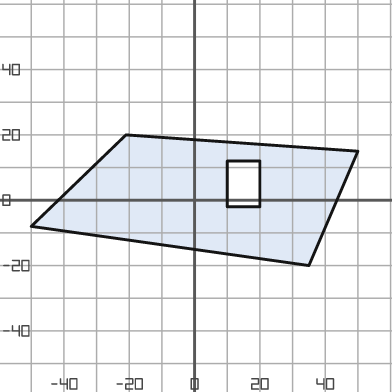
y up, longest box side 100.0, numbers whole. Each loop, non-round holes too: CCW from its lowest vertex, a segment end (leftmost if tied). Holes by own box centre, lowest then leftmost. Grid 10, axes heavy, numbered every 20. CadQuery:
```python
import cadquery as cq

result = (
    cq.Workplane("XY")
    .moveTo(35.0, -20.0)
    .lineTo(50.0, 15.0)
    .lineTo(-21.0, 20.0)
    .lineTo(-50.0, -8.0)
    .close()
    .moveTo(10.0, -2.0)
    .lineTo(20.0, -2.0)
    .lineTo(20.0, 12.0)
    .lineTo(10.0, 12.0)
    .close()
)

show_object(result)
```